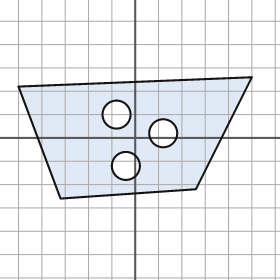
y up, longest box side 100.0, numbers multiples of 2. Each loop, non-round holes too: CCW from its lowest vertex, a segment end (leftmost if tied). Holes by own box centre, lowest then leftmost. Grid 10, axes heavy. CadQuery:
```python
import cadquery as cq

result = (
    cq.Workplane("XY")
    .moveTo(-32.0, -26.0)
    .lineTo(26.0, -22.0)
    .lineTo(50.0, 26.0)
    .lineTo(-50.0, 22.0)
    .close()
    .moveTo(-4.0, -12.0)
    .circle(6.0)
    .moveTo(12.0, 2.0)
    .circle(6.0)
    .moveTo(-8.0, 10.0)
    .circle(6.0)
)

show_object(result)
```